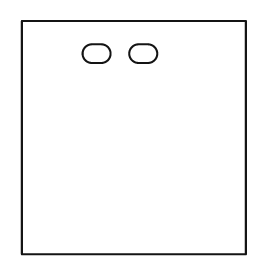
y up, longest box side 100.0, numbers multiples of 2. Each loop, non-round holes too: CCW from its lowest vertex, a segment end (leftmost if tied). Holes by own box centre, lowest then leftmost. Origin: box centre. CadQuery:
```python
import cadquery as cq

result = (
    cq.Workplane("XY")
    .moveTo(-48.0, -50.0)
    .lineTo(48.0, -50.0)
    .lineTo(48.0, 50.0)
    .lineTo(-48.0, 50.0)
    .close()
    .moveTo(-18.0, 32.0)
    .lineTo(-14.0, 32.0)
    .threePointArc((-10.0, 36.0), (-14.0, 40.0))
    .lineTo(-18.0, 40.0)
    .threePointArc((-22.0, 36.0), (-18.0, 32.0))
    .close()
    .moveTo(2.0, 32.0)
    .lineTo(6.0, 32.0)
    .threePointArc((10.0, 36.0), (6.0, 40.0))
    .lineTo(2.0, 40.0)
    .threePointArc((-2.0, 36.0), (2.0, 32.0))
    .close()
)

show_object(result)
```